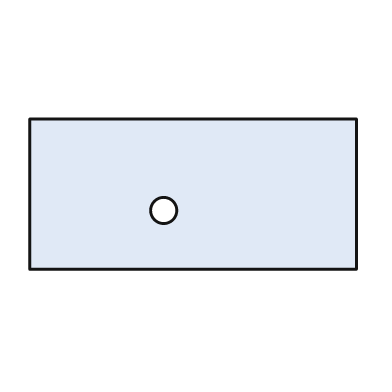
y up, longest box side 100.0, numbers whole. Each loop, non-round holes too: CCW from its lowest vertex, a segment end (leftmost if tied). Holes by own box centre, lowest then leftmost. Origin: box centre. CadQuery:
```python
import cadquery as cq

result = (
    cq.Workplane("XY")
    .moveTo(-50.0, -23.0)
    .lineTo(50.0, -23.0)
    .lineTo(50.0, 23.0)
    .lineTo(-50.0, 23.0)
    .close()
    .moveTo(-9.0, -5.0)
    .circle(4.0)
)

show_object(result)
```